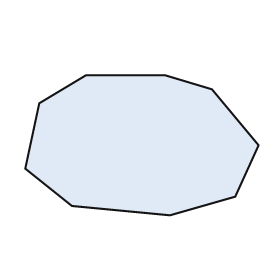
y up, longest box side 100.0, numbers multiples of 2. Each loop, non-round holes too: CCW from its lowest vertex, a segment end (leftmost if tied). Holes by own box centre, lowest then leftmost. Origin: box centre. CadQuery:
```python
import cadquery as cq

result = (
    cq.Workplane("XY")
    .moveTo(12.0, -30.0)
    .lineTo(40.0, -22.0)
    .lineTo(50.0, 0.0)
    .lineTo(30.0, 24.0)
    .lineTo(10.0, 30.0)
    .lineTo(-24.0, 30.0)
    .lineTo(-44.0, 18.0)
    .lineTo(-50.0, -10.0)
    .lineTo(-30.0, -26.0)
    .close()
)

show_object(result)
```